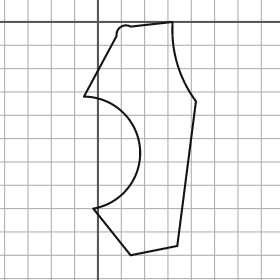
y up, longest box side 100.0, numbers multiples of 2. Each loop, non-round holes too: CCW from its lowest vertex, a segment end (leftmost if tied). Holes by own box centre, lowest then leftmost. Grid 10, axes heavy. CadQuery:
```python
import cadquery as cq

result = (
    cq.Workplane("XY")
    .moveTo(14.0, -100.0)
    .lineTo(34.0, -96.0)
    .lineTo(42.0, -34.0)
    .threePointArc((34.0, -18.0), (32.0, 0.0))
    .lineTo(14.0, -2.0)
    .threePointArc((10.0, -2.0), (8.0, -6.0))
    .lineTo(-6.0, -32.0)
    .threePointArc((18.0, -54.0), (-2.0, -80.0))
    .close()
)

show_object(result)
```